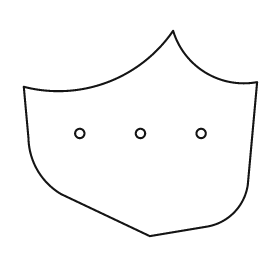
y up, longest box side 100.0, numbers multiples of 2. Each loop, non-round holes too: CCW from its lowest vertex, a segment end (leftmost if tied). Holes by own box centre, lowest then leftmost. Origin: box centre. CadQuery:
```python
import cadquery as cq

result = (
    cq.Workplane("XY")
    .moveTo(4.0, -44.0)
    .lineTo(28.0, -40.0)
    .threePointArc((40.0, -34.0), (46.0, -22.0))
    .lineTo(50.0, 22.0)
    .threePointArc((28.0, 26.0), (14.0, 44.0))
    .threePointArc((-14.0, 22.0), (-50.0, 20.0))
    .lineTo(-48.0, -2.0)
    .threePointArc((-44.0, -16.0), (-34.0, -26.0))
    .close()
    .moveTo(-26.0, 0.0)
    .circle(2.0)
    .moveTo(0.0, 0.0)
    .circle(2.0)
    .moveTo(26.0, 0.0)
    .circle(2.0)
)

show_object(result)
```